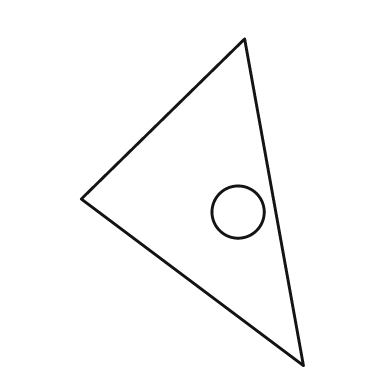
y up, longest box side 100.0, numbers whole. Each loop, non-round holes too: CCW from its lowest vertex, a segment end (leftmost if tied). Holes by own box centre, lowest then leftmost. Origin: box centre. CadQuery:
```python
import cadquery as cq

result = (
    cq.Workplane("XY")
    .moveTo(34.0, -50.0)
    .lineTo(16.0, 50.0)
    .lineTo(-34.0, 1.0)
    .close()
    .moveTo(14.0, -3.0)
    .circle(8.0)
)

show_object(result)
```